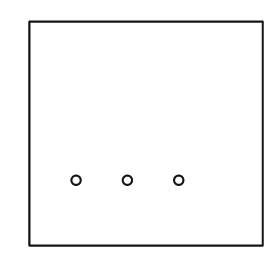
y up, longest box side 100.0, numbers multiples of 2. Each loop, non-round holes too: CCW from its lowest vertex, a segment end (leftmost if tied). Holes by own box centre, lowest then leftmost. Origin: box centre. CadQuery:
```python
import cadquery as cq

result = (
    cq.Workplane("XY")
    .moveTo(-50.0, -48.0)
    .lineTo(50.0, -48.0)
    .lineTo(50.0, 48.0)
    .lineTo(-50.0, 48.0)
    .close()
    .moveTo(-30.0, -20.0)
    .circle(2.0)
    .moveTo(-8.0, -20.0)
    .circle(2.0)
    .moveTo(14.0, -20.0)
    .circle(2.0)
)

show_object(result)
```